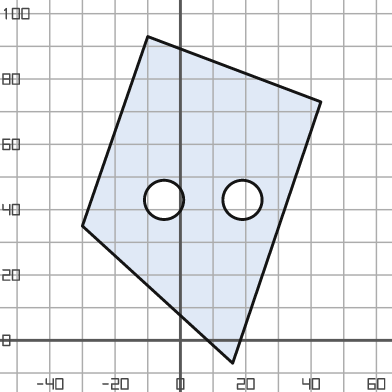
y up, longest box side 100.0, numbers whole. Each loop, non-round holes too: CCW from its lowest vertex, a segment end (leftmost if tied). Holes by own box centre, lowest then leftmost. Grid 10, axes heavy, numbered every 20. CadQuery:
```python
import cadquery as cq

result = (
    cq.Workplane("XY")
    .moveTo(16.0, -7.0)
    .lineTo(43.0, 73.0)
    .lineTo(-10.0, 93.0)
    .lineTo(-30.0, 35.0)
    .close()
    .moveTo(-5.0, 43.0)
    .circle(6.0)
    .moveTo(19.0, 43.0)
    .circle(6.0)
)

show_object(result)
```